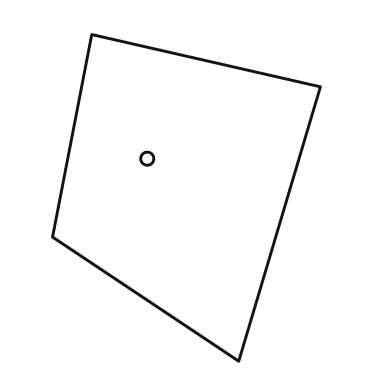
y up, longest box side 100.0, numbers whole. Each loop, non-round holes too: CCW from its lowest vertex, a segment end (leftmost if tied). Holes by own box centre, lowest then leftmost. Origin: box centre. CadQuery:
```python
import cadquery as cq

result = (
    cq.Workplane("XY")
    .moveTo(16.0, -50.0)
    .lineTo(41.0, 34.0)
    .lineTo(-29.0, 50.0)
    .lineTo(-41.0, -12.0)
    .close()
    .moveTo(-12.0, 12.0)
    .circle(2.0)
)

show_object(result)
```